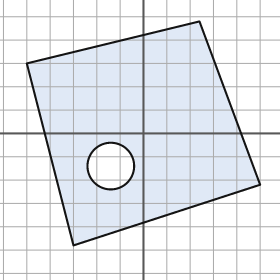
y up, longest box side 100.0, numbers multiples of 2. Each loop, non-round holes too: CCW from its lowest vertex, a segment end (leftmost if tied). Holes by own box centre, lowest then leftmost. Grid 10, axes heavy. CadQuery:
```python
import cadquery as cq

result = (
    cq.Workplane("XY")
    .moveTo(-30.0, -48.0)
    .lineTo(50.0, -22.0)
    .lineTo(24.0, 48.0)
    .lineTo(-50.0, 30.0)
    .close()
    .moveTo(-14.0, -14.0)
    .circle(10.0)
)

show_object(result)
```